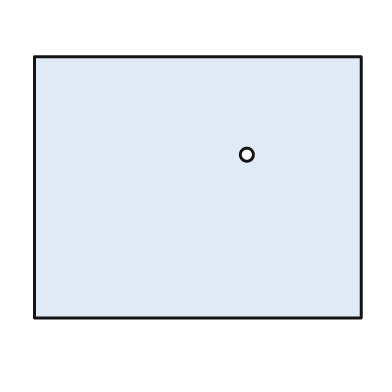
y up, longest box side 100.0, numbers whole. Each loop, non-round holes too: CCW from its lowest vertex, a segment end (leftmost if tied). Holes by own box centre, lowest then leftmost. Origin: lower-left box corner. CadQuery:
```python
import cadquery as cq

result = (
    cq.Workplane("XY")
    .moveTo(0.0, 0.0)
    .lineTo(100.0, 0.0)
    .lineTo(100.0, 80.0)
    .lineTo(0.0, 80.0)
    .close()
    .moveTo(65.0, 50.0)
    .circle(2.0)
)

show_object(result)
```